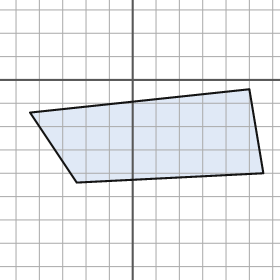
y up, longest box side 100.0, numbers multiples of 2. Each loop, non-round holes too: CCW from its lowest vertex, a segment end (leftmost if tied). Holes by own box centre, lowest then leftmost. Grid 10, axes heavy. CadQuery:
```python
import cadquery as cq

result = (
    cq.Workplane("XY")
    .moveTo(-24.0, -44.0)
    .lineTo(56.0, -40.0)
    .lineTo(50.0, -4.0)
    .lineTo(-44.0, -14.0)
    .close()
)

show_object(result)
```